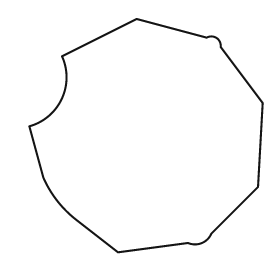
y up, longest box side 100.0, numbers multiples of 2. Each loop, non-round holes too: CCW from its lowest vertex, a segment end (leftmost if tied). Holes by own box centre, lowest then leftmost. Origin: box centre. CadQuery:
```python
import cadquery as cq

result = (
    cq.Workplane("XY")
    .moveTo(-12.0, -50.0)
    .lineTo(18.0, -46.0)
    .threePointArc((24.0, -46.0), (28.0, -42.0))
    .lineTo(48.0, -22.0)
    .lineTo(50.0, 14.0)
    .lineTo(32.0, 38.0)
    .threePointArc((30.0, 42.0), (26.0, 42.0))
    .lineTo(-4.0, 50.0)
    .lineTo(-36.0, 34.0)
    .threePointArc((-36.0, 16.0), (-50.0, 4.0))
    .lineTo(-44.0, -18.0)
    .threePointArc((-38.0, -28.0), (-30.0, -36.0))
    .close()
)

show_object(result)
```